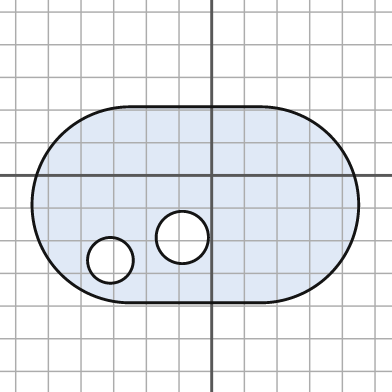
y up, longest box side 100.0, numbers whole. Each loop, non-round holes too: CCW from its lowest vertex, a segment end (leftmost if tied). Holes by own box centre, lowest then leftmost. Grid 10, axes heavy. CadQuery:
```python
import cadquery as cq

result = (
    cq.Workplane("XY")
    .moveTo(-25.0, -39.0)
    .lineTo(15.0, -39.0)
    .threePointArc((45.0, -9.0), (15.0, 21.0))
    .lineTo(-25.0, 21.0)
    .threePointArc((-55.0, -9.0), (-25.0, -39.0))
    .close()
    .moveTo(-31.0, -26.0)
    .circle(7.0)
    .moveTo(-9.0, -19.0)
    .circle(8.0)
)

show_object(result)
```